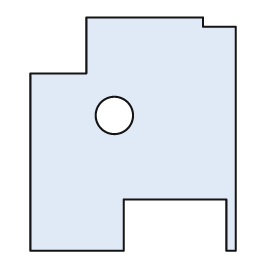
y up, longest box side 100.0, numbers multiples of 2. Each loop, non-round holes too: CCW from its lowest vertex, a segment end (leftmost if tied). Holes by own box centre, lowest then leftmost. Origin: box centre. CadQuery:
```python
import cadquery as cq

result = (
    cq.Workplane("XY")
    .moveTo(-44.0, -50.0)
    .lineTo(-4.0, -50.0)
    .lineTo(-4.0, -28.0)
    .lineTo(40.0, -28.0)
    .lineTo(40.0, -50.0)
    .lineTo(44.0, -50.0)
    .lineTo(44.0, 46.0)
    .lineTo(30.0, 46.0)
    .lineTo(30.0, 50.0)
    .lineTo(-20.0, 50.0)
    .lineTo(-20.0, 26.0)
    .lineTo(-44.0, 26.0)
    .close()
    .moveTo(-8.0, 8.0)
    .circle(8.0)
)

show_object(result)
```